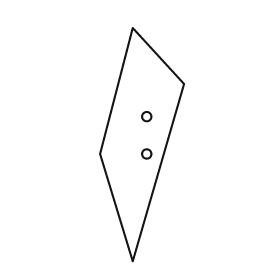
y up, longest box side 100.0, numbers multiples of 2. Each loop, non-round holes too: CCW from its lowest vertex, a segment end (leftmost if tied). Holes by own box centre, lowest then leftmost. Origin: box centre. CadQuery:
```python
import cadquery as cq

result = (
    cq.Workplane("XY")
    .moveTo(-4.0, -50.0)
    .lineTo(18.0, 26.0)
    .lineTo(-4.0, 50.0)
    .lineTo(-18.0, -4.0)
    .close()
    .moveTo(2.0, -4.0)
    .circle(2.0)
    .moveTo(2.0, 12.0)
    .circle(2.0)
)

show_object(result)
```